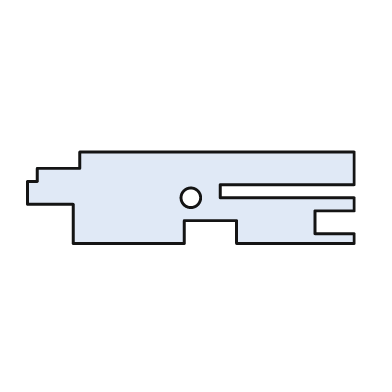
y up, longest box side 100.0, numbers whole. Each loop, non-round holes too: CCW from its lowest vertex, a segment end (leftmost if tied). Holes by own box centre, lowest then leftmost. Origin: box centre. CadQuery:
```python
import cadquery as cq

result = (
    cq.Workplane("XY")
    .moveTo(-36.0, -14.0)
    .lineTo(-2.0, -14.0)
    .lineTo(-2.0, -7.0)
    .lineTo(14.0, -7.0)
    .lineTo(14.0, -14.0)
    .lineTo(50.0, -14.0)
    .lineTo(50.0, -11.0)
    .lineTo(38.0, -11.0)
    .lineTo(38.0, -4.0)
    .lineTo(50.0, -4.0)
    .lineTo(50.0, 0.0)
    .lineTo(9.0, 0.0)
    .lineTo(9.0, 4.0)
    .lineTo(50.0, 4.0)
    .lineTo(50.0, 14.0)
    .lineTo(-34.0, 14.0)
    .lineTo(-34.0, 9.0)
    .lineTo(-47.0, 9.0)
    .lineTo(-47.0, 5.0)
    .lineTo(-50.0, 5.0)
    .lineTo(-50.0, -2.0)
    .lineTo(-36.0, -2.0)
    .close()
    .moveTo(0.0, 0.0)
    .circle(3.0)
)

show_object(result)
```